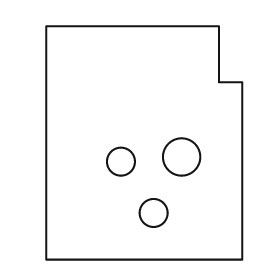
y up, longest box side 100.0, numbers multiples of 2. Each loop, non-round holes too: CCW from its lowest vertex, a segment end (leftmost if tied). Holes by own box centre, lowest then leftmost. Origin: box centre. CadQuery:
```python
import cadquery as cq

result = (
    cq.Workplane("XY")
    .moveTo(-42.0, -50.0)
    .lineTo(42.0, -50.0)
    .lineTo(42.0, 26.0)
    .lineTo(32.0, 26.0)
    .lineTo(32.0, 50.0)
    .lineTo(-42.0, 50.0)
    .close()
    .moveTo(4.0, -30.0)
    .circle(6.0)
    .moveTo(-10.0, -8.0)
    .circle(6.0)
    .moveTo(16.0, -6.0)
    .circle(8.0)
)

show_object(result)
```